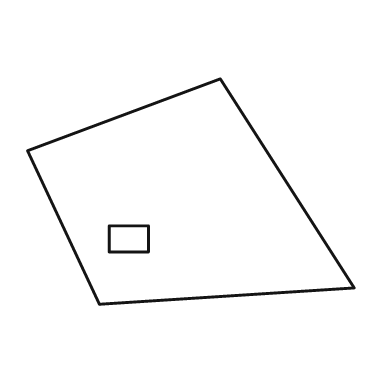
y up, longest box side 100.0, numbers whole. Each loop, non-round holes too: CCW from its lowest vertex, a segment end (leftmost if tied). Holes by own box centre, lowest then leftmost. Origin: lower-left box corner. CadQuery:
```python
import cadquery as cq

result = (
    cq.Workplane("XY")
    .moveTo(22.0, 0.0)
    .lineTo(100.0, 5.0)
    .lineTo(59.0, 69.0)
    .lineTo(0.0, 47.0)
    .close()
    .moveTo(25.0, 16.0)
    .lineTo(37.0, 16.0)
    .lineTo(37.0, 24.0)
    .lineTo(25.0, 24.0)
    .close()
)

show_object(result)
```